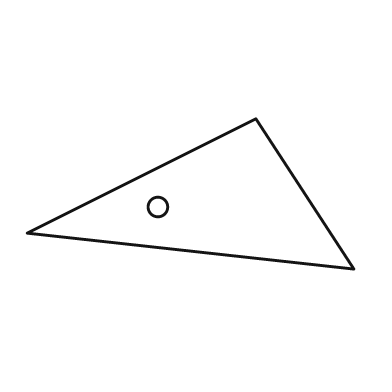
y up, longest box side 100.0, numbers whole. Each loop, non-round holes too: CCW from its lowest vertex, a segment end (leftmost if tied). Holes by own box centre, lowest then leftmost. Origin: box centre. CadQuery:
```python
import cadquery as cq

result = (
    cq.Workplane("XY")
    .moveTo(50.0, -23.0)
    .lineTo(20.0, 23.0)
    .lineTo(-50.0, -12.0)
    .close()
    .moveTo(-10.0, -4.0)
    .circle(3.0)
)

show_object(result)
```